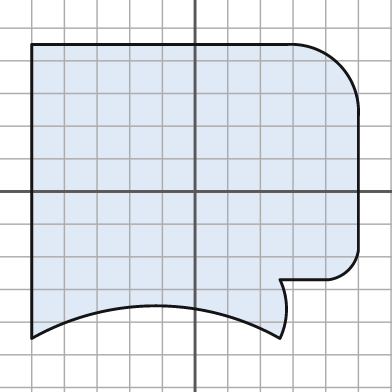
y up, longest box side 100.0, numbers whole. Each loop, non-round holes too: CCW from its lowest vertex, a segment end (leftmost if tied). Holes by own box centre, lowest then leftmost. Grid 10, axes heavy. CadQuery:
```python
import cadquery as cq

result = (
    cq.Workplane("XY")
    .moveTo(-50.0, -45.0)
    .threePointArc((-12.0, -35.0), (26.0, -45.0))
    .threePointArc((28.0, -36.0), (26.0, -27.0))
    .lineTo(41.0, -27.0)
    .threePointArc((47.0, -24.0), (50.0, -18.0))
    .lineTo(50.0, 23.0)
    .threePointArc((44.0, 39.0), (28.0, 45.0))
    .lineTo(-50.0, 45.0)
    .close()
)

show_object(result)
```